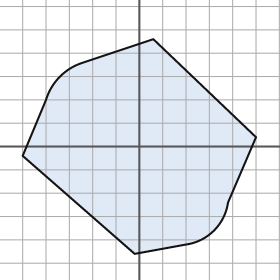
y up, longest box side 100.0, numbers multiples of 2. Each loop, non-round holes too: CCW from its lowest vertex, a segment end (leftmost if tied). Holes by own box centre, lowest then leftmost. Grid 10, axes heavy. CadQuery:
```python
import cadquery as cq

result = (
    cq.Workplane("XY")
    .moveTo(-2.0, -46.0)
    .lineTo(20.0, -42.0)
    .threePointArc((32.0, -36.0), (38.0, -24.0))
    .lineTo(50.0, 4.0)
    .lineTo(6.0, 46.0)
    .lineTo(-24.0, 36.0)
    .threePointArc((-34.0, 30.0), (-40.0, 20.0))
    .lineTo(-50.0, -4.0)
    .close()
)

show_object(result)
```